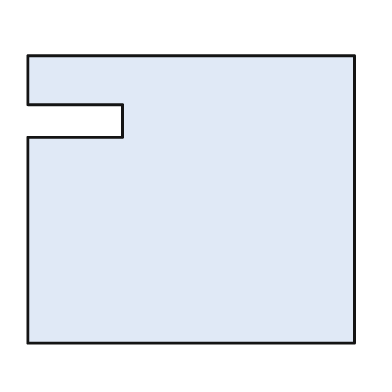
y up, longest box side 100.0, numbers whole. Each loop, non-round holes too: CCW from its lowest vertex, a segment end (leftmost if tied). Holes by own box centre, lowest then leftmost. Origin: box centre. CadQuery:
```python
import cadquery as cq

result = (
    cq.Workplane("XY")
    .moveTo(-50.0, -44.0)
    .lineTo(50.0, -44.0)
    .lineTo(50.0, 44.0)
    .lineTo(-50.0, 44.0)
    .lineTo(-50.0, 29.0)
    .lineTo(-21.0, 29.0)
    .lineTo(-21.0, 19.0)
    .lineTo(-50.0, 19.0)
    .close()
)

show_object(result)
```